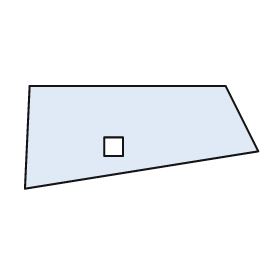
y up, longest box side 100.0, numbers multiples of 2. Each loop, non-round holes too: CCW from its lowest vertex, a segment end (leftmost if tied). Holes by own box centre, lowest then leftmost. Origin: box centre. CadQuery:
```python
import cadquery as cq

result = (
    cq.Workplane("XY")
    .moveTo(-50.0, -22.0)
    .lineTo(50.0, -6.0)
    .lineTo(36.0, 22.0)
    .lineTo(-48.0, 22.0)
    .close()
    .moveTo(-16.0, -8.0)
    .lineTo(-8.0, -8.0)
    .lineTo(-8.0, 0.0)
    .lineTo(-16.0, 0.0)
    .close()
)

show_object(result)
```